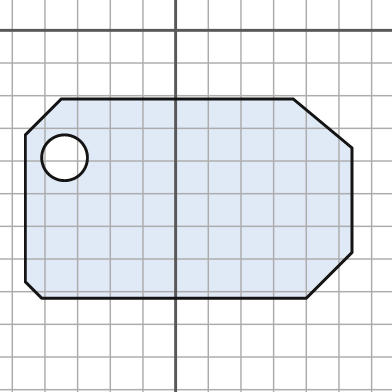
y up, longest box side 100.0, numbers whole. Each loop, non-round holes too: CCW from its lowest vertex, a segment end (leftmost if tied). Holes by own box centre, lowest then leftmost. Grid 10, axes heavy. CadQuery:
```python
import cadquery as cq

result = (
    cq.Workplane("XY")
    .moveTo(-41.0, -82.0)
    .lineTo(40.0, -82.0)
    .lineTo(54.0, -68.0)
    .lineTo(54.0, -36.0)
    .lineTo(36.0, -21.0)
    .lineTo(-35.0, -21.0)
    .lineTo(-46.0, -32.0)
    .lineTo(-46.0, -77.0)
    .close()
    .moveTo(-34.0, -39.0)
    .circle(7.0)
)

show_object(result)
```